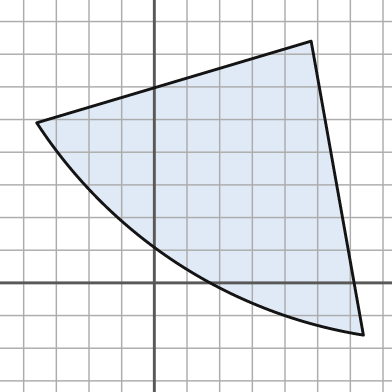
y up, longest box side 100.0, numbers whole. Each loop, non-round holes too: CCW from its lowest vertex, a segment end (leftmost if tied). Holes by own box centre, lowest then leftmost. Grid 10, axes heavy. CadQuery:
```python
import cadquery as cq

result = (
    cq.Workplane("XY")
    .moveTo(64.0, -16.0)
    .lineTo(48.0, 74.0)
    .lineTo(-36.0, 49.0)
    .threePointArc((7.0, 6.0), (64.0, -16.0))
    .close()
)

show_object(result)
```